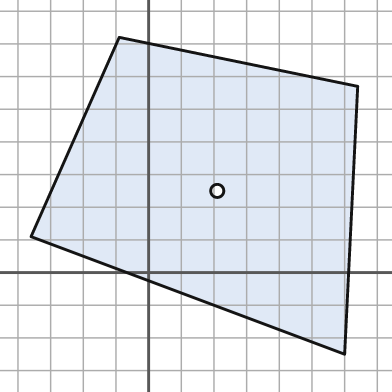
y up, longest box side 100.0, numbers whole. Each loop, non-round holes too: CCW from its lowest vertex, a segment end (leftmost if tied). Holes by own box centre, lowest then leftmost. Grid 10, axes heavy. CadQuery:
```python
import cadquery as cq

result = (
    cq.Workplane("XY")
    .moveTo(60.0, -25.0)
    .lineTo(64.0, 57.0)
    .lineTo(-9.0, 72.0)
    .lineTo(-36.0, 11.0)
    .close()
    .moveTo(21.0, 25.0)
    .circle(2.0)
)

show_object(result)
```